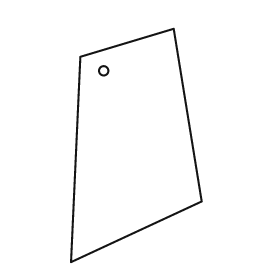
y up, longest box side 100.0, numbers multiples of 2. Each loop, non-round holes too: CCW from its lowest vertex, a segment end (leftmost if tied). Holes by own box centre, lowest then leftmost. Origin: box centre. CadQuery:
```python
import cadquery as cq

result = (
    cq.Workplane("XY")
    .moveTo(-28.0, -50.0)
    .lineTo(28.0, -24.0)
    .lineTo(16.0, 50.0)
    .lineTo(-24.0, 38.0)
    .close()
    .moveTo(-14.0, 32.0)
    .circle(2.0)
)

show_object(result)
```